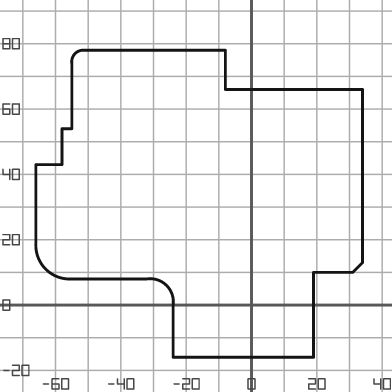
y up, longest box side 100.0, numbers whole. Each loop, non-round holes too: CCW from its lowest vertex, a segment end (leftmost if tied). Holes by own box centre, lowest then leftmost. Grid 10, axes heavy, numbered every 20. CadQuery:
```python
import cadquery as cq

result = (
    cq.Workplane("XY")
    .moveTo(-24.0, -16.0)
    .lineTo(19.0, -16.0)
    .lineTo(19.0, 10.0)
    .lineTo(31.0, 10.0)
    .lineTo(34.0, 13.0)
    .lineTo(34.0, 66.0)
    .lineTo(-8.0, 66.0)
    .lineTo(-8.0, 78.0)
    .lineTo(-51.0, 78.0)
    .threePointArc((-54.0, 77.0), (-55.0, 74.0))
    .lineTo(-55.0, 54.0)
    .lineTo(-58.0, 54.0)
    .lineTo(-58.0, 43.0)
    .lineTo(-66.0, 43.0)
    .lineTo(-66.0, 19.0)
    .threePointArc((-63.0, 11.0), (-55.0, 8.0))
    .lineTo(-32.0, 8.0)
    .threePointArc((-26.0, 6.0), (-24.0, 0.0))
    .close()
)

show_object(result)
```